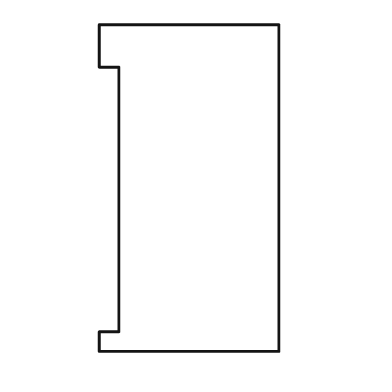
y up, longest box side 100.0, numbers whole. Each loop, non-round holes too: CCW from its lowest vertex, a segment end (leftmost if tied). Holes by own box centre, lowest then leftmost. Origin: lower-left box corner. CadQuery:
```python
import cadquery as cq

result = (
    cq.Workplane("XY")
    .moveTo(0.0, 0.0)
    .lineTo(55.0, 0.0)
    .lineTo(55.0, 100.0)
    .lineTo(0.0, 100.0)
    .lineTo(0.0, 87.0)
    .lineTo(6.0, 87.0)
    .lineTo(6.0, 6.0)
    .lineTo(0.0, 6.0)
    .close()
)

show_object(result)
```